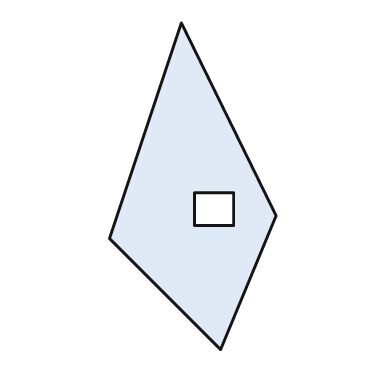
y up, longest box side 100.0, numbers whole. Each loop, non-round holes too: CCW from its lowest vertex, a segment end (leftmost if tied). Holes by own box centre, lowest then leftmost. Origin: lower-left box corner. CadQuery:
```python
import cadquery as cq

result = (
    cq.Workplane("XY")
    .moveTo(34.0, 0.0)
    .lineTo(51.0, 41.0)
    .lineTo(22.0, 100.0)
    .lineTo(0.0, 34.0)
    .close()
    .moveTo(26.0, 38.0)
    .lineTo(38.0, 38.0)
    .lineTo(38.0, 48.0)
    .lineTo(26.0, 48.0)
    .close()
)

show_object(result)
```